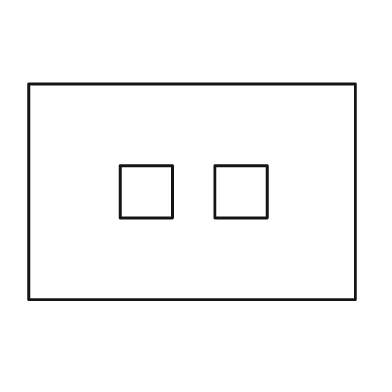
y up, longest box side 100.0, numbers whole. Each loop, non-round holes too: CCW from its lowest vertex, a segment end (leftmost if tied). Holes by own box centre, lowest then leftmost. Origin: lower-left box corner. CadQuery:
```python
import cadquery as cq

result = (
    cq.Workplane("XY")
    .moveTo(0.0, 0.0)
    .lineTo(100.0, 0.0)
    .lineTo(100.0, 66.0)
    .lineTo(0.0, 66.0)
    .close()
    .moveTo(28.0, 25.0)
    .lineTo(44.0, 25.0)
    .lineTo(44.0, 41.0)
    .lineTo(28.0, 41.0)
    .close()
    .moveTo(57.0, 25.0)
    .lineTo(73.0, 25.0)
    .lineTo(73.0, 41.0)
    .lineTo(57.0, 41.0)
    .close()
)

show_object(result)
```